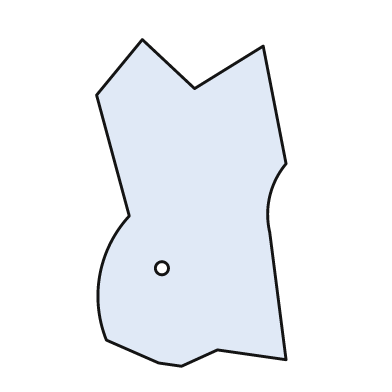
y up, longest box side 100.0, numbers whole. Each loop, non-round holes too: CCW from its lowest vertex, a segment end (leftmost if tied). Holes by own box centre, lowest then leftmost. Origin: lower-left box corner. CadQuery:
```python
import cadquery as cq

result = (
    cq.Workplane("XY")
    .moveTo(26.0, 0.0)
    .lineTo(37.0, 5.0)
    .lineTo(58.0, 2.0)
    .lineTo(53.0, 41.0)
    .threePointArc((53.0, 52.0), (58.0, 62.0))
    .lineTo(51.0, 98.0)
    .lineTo(30.0, 85.0)
    .lineTo(14.0, 100.0)
    .lineTo(0.0, 83.0)
    .lineTo(10.0, 46.0)
    .threePointArc((1.0, 28.0), (3.0, 8.0))
    .lineTo(19.0, 1.0)
    .close()
    .moveTo(20.0, 30.0)
    .circle(2.0)
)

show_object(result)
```